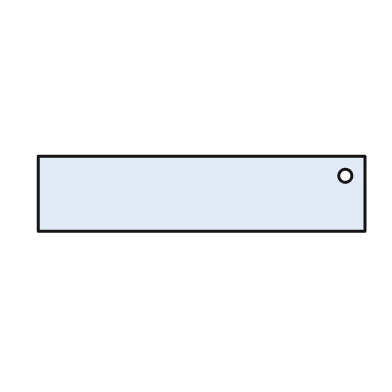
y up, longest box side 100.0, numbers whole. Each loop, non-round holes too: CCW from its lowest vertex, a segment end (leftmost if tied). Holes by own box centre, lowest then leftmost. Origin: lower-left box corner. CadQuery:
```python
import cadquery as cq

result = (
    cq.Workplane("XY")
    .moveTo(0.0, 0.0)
    .lineTo(100.0, 0.0)
    .lineTo(100.0, 23.0)
    .lineTo(0.0, 23.0)
    .close()
    .moveTo(94.0, 17.0)
    .circle(2.0)
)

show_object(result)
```